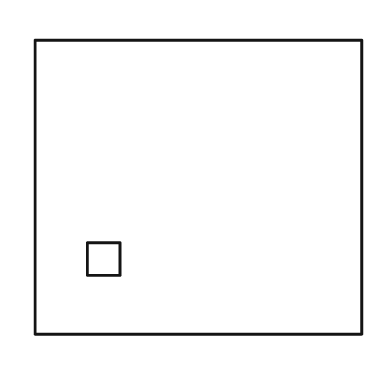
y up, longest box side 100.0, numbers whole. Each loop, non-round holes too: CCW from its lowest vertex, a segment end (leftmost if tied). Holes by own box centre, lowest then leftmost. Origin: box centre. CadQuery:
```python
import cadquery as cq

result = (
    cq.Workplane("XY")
    .moveTo(-50.0, -45.0)
    .lineTo(50.0, -45.0)
    .lineTo(50.0, 45.0)
    .lineTo(-50.0, 45.0)
    .close()
    .moveTo(-34.0, -27.0)
    .lineTo(-24.0, -27.0)
    .lineTo(-24.0, -17.0)
    .lineTo(-34.0, -17.0)
    .close()
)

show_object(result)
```